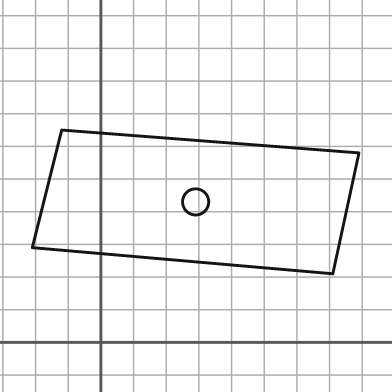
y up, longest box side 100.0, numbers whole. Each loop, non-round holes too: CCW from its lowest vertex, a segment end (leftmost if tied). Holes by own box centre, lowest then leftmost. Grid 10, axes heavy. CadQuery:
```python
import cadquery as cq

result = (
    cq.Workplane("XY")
    .moveTo(71.0, 21.0)
    .lineTo(79.0, 58.0)
    .lineTo(-12.0, 65.0)
    .lineTo(-21.0, 29.0)
    .close()
    .moveTo(29.0, 43.0)
    .circle(4.0)
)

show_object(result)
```